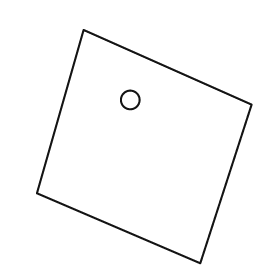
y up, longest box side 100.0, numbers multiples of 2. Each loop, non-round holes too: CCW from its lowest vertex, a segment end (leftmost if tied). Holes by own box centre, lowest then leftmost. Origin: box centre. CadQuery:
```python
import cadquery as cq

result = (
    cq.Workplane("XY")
    .moveTo(24.0, -50.0)
    .lineTo(46.0, 18.0)
    .lineTo(-26.0, 50.0)
    .lineTo(-46.0, -20.0)
    .close()
    .moveTo(-6.0, 20.0)
    .circle(4.0)
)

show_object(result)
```